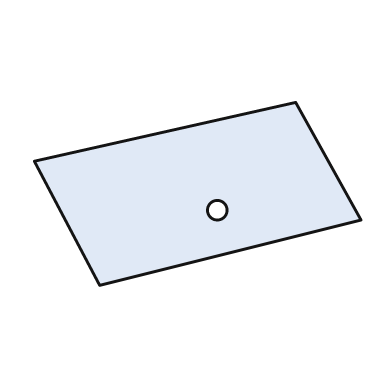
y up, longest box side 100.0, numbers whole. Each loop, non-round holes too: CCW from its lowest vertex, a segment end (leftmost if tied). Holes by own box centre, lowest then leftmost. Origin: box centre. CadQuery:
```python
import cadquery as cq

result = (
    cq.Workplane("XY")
    .moveTo(-30.0, -28.0)
    .lineTo(50.0, -8.0)
    .lineTo(30.0, 28.0)
    .lineTo(-50.0, 10.0)
    .close()
    .moveTo(6.0, -5.0)
    .circle(3.0)
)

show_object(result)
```